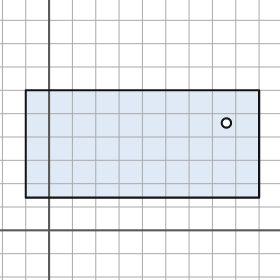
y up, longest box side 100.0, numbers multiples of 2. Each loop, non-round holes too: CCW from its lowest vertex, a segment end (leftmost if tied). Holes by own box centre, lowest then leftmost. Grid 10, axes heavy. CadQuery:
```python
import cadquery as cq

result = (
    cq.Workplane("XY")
    .moveTo(-10.0, 14.0)
    .lineTo(90.0, 14.0)
    .lineTo(90.0, 60.0)
    .lineTo(-10.0, 60.0)
    .close()
    .moveTo(76.0, 46.0)
    .circle(2.0)
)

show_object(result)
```